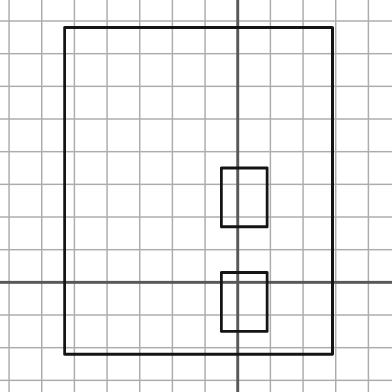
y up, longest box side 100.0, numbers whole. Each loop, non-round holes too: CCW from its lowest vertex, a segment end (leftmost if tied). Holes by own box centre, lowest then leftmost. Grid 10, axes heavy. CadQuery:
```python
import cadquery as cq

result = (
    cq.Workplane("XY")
    .moveTo(-53.0, -22.0)
    .lineTo(29.0, -22.0)
    .lineTo(29.0, 78.0)
    .lineTo(-53.0, 78.0)
    .close()
    .moveTo(-5.0, -15.0)
    .lineTo(9.0, -15.0)
    .lineTo(9.0, 3.0)
    .lineTo(-5.0, 3.0)
    .close()
    .moveTo(-5.0, 17.0)
    .lineTo(9.0, 17.0)
    .lineTo(9.0, 35.0)
    .lineTo(-5.0, 35.0)
    .close()
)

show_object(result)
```